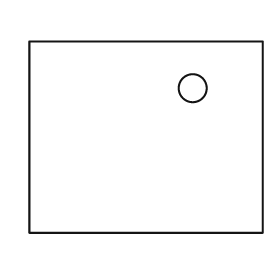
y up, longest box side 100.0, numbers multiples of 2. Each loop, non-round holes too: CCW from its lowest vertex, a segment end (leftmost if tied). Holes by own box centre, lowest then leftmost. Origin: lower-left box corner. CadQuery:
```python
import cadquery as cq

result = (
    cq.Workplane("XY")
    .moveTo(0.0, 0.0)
    .lineTo(100.0, 0.0)
    .lineTo(100.0, 82.0)
    .lineTo(0.0, 82.0)
    .close()
    .moveTo(70.0, 62.0)
    .circle(6.0)
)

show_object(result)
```